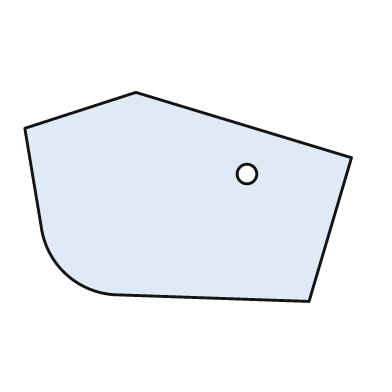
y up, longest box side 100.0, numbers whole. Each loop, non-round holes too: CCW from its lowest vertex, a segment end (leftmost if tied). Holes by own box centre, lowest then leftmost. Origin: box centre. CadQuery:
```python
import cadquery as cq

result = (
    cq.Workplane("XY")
    .moveTo(37.0, -32.0)
    .lineTo(50.0, 12.0)
    .lineTo(-16.0, 32.0)
    .lineTo(-50.0, 21.0)
    .lineTo(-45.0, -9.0)
    .threePointArc((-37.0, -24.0), (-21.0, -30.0))
    .close()
    .moveTo(18.0, 7.0)
    .circle(3.0)
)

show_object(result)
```